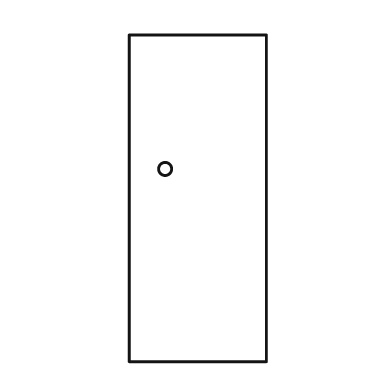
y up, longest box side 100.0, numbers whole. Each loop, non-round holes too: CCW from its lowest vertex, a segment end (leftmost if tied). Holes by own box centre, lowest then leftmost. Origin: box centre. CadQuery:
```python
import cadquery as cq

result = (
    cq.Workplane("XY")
    .moveTo(-21.0, -50.0)
    .lineTo(21.0, -50.0)
    .lineTo(21.0, 50.0)
    .lineTo(-21.0, 50.0)
    .close()
    .moveTo(-10.0, 9.0)
    .circle(2.0)
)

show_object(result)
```